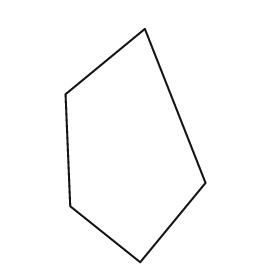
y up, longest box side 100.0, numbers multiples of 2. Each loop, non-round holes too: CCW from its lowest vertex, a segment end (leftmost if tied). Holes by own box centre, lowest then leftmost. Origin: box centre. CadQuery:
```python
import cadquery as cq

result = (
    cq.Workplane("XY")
    .moveTo(2.0, -50.0)
    .lineTo(30.0, -16.0)
    .lineTo(4.0, 50.0)
    .lineTo(-30.0, 22.0)
    .lineTo(-28.0, -26.0)
    .close()
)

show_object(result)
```